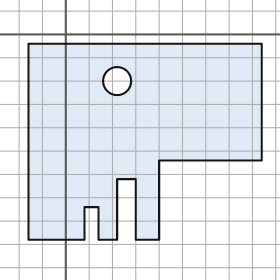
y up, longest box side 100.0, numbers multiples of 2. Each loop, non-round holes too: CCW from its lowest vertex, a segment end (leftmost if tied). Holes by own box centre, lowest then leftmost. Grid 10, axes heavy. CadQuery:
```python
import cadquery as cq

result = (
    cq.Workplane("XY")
    .moveTo(-16.0, -88.0)
    .lineTo(8.0, -88.0)
    .lineTo(8.0, -74.0)
    .lineTo(14.0, -74.0)
    .lineTo(14.0, -88.0)
    .lineTo(22.0, -88.0)
    .lineTo(22.0, -62.0)
    .lineTo(30.0, -62.0)
    .lineTo(30.0, -88.0)
    .lineTo(40.0, -88.0)
    .lineTo(40.0, -54.0)
    .lineTo(84.0, -54.0)
    .lineTo(84.0, -4.0)
    .lineTo(-16.0, -4.0)
    .close()
    .moveTo(22.0, -20.0)
    .circle(6.0)
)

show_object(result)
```